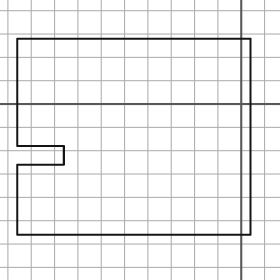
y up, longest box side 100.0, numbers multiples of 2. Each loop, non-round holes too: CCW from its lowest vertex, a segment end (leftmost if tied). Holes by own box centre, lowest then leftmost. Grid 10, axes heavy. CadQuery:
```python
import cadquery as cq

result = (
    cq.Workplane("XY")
    .moveTo(-96.0, -56.0)
    .lineTo(4.0, -56.0)
    .lineTo(4.0, 28.0)
    .lineTo(-96.0, 28.0)
    .lineTo(-96.0, -18.0)
    .lineTo(-76.0, -18.0)
    .lineTo(-76.0, -26.0)
    .lineTo(-96.0, -26.0)
    .close()
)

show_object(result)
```